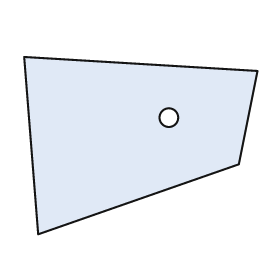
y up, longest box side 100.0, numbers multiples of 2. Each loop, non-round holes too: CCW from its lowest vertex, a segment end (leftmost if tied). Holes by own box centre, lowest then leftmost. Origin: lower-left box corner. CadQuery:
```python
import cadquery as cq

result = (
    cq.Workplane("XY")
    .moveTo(6.0, 0.0)
    .lineTo(92.0, 30.0)
    .lineTo(100.0, 70.0)
    .lineTo(0.0, 76.0)
    .close()
    .moveTo(62.0, 50.0)
    .circle(4.0)
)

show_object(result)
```